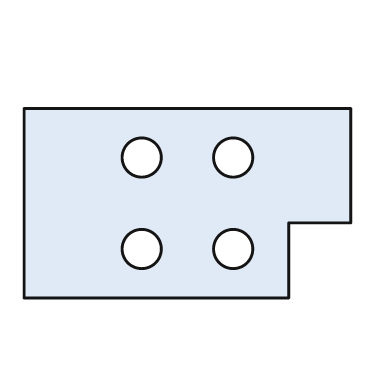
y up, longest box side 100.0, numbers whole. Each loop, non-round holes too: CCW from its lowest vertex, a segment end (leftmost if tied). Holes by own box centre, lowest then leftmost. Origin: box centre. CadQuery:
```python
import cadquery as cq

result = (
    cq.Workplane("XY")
    .moveTo(-50.0, -29.0)
    .lineTo(31.0, -29.0)
    .lineTo(31.0, -6.0)
    .lineTo(50.0, -6.0)
    .lineTo(50.0, 29.0)
    .lineTo(-50.0, 29.0)
    .close()
    .moveTo(-14.0, -14.0)
    .circle(6.0)
    .moveTo(14.0, -14.0)
    .circle(6.0)
    .moveTo(-14.0, 14.0)
    .circle(6.0)
    .moveTo(14.0, 14.0)
    .circle(6.0)
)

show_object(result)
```